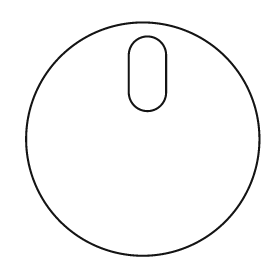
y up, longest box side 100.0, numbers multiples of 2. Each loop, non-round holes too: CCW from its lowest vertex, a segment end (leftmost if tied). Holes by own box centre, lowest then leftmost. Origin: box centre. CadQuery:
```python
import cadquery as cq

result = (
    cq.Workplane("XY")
    .moveTo(0.0, 0.0)
    .circle(50.0)
    .moveTo(-6.0, 20.0)
    .threePointArc((2.0, 12.0), (10.0, 20.0))
    .lineTo(10.0, 36.0)
    .threePointArc((2.0, 44.0), (-6.0, 36.0))
    .close()
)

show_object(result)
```